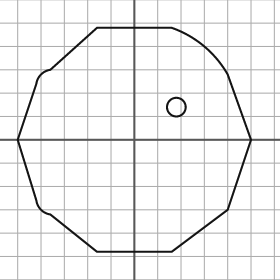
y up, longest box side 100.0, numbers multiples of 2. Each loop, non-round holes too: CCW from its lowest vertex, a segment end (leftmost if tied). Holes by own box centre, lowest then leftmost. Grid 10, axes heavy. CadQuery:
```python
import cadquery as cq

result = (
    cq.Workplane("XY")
    .moveTo(-16.0, -48.0)
    .lineTo(16.0, -48.0)
    .lineTo(40.0, -30.0)
    .lineTo(50.0, 0.0)
    .lineTo(40.0, 28.0)
    .threePointArc((30.0, 40.0), (16.0, 48.0))
    .lineTo(-16.0, 48.0)
    .lineTo(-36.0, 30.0)
    .threePointArc((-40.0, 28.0), (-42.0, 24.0))
    .lineTo(-50.0, 0.0)
    .lineTo(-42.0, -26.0)
    .threePointArc((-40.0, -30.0), (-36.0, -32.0))
    .close()
    .moveTo(18.0, 14.0)
    .circle(4.0)
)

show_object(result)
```